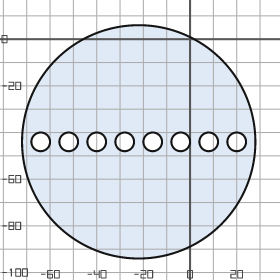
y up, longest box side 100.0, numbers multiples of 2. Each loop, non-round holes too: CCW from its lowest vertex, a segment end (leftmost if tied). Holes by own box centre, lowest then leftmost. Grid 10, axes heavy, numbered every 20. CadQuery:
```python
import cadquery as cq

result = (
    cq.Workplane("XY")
    .moveTo(-22.0, -44.0)
    .circle(50.0)
    .moveTo(-64.0, -44.0)
    .circle(4.0)
    .moveTo(-52.0, -44.0)
    .circle(4.0)
    .moveTo(-40.0, -44.0)
    .circle(4.0)
    .moveTo(-28.0, -44.0)
    .circle(4.0)
    .moveTo(-16.0, -44.0)
    .circle(4.0)
    .moveTo(-4.0, -44.0)
    .circle(4.0)
    .moveTo(8.0, -44.0)
    .circle(4.0)
    .moveTo(20.0, -44.0)
    .circle(4.0)
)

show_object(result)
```